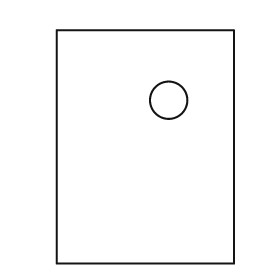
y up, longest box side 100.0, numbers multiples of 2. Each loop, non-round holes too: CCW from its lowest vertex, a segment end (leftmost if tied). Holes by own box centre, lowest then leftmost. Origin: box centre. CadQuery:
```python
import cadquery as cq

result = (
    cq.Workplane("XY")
    .moveTo(-38.0, -50.0)
    .lineTo(38.0, -50.0)
    .lineTo(38.0, 50.0)
    .lineTo(-38.0, 50.0)
    .close()
    .moveTo(10.0, 20.0)
    .circle(8.0)
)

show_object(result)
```